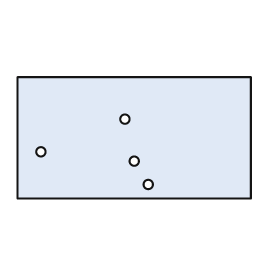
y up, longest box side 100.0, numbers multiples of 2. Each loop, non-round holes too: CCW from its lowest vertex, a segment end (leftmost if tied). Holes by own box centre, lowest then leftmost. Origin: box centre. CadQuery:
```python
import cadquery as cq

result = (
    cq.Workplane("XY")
    .moveTo(-50.0, -26.0)
    .lineTo(50.0, -26.0)
    .lineTo(50.0, 26.0)
    .lineTo(-50.0, 26.0)
    .close()
    .moveTo(6.0, -20.0)
    .circle(2.0)
    .moveTo(0.0, -10.0)
    .circle(2.0)
    .moveTo(-40.0, -6.0)
    .circle(2.0)
    .moveTo(-4.0, 8.0)
    .circle(2.0)
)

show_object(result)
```